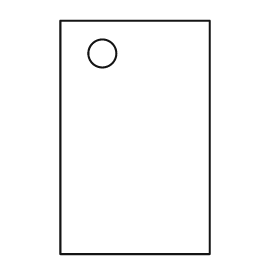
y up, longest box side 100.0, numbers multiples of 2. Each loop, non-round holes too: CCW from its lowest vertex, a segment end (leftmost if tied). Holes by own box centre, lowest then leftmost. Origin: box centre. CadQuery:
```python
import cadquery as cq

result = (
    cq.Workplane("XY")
    .moveTo(-32.0, -50.0)
    .lineTo(32.0, -50.0)
    .lineTo(32.0, 50.0)
    .lineTo(-32.0, 50.0)
    .close()
    .moveTo(-14.0, 36.0)
    .circle(6.0)
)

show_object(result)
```